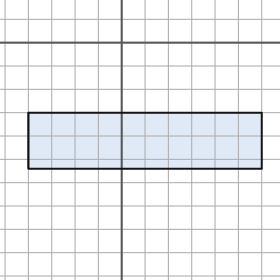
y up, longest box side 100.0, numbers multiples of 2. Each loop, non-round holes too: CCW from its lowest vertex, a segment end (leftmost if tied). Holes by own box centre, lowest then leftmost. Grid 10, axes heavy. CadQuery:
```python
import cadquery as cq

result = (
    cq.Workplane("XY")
    .moveTo(-40.0, -54.0)
    .lineTo(60.0, -54.0)
    .lineTo(60.0, -30.0)
    .lineTo(-40.0, -30.0)
    .close()
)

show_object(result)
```